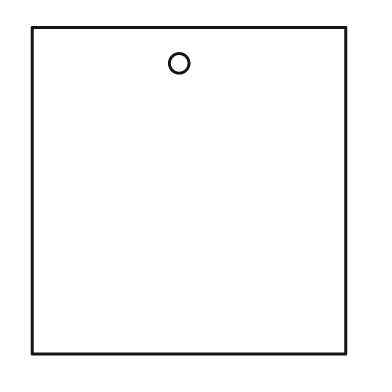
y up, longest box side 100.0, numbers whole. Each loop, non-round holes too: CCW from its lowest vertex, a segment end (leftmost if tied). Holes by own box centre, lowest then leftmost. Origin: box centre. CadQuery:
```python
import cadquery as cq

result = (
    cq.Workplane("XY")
    .moveTo(-48.0, -50.0)
    .lineTo(48.0, -50.0)
    .lineTo(48.0, 50.0)
    .lineTo(-48.0, 50.0)
    .close()
    .moveTo(-3.0, 39.0)
    .circle(3.0)
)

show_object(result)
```